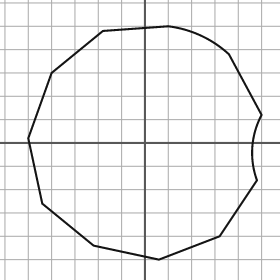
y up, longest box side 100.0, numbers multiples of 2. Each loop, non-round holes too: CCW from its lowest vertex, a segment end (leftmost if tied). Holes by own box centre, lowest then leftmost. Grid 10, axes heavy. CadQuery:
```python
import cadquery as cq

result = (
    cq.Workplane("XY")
    .moveTo(6.0, -50.0)
    .lineTo(32.0, -40.0)
    .lineTo(48.0, -16.0)
    .threePointArc((46.0, -2.0), (50.0, 12.0))
    .lineTo(36.0, 38.0)
    .threePointArc((24.0, 46.0), (10.0, 50.0))
    .lineTo(-18.0, 48.0)
    .lineTo(-40.0, 30.0)
    .lineTo(-50.0, 2.0)
    .lineTo(-44.0, -26.0)
    .lineTo(-22.0, -44.0)
    .close()
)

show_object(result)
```